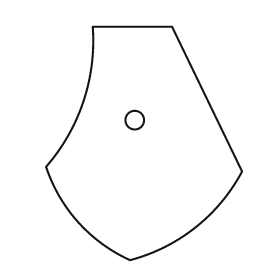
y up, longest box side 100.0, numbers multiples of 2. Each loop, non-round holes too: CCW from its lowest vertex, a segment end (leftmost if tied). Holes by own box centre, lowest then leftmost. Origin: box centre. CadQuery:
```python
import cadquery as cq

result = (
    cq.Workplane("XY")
    .moveTo(-6.0, -50.0)
    .threePointArc((22.0, -36.0), (42.0, -12.0))
    .lineTo(12.0, 50.0)
    .lineTo(-22.0, 50.0)
    .threePointArc((-26.0, 18.0), (-42.0, -10.0))
    .threePointArc((-28.0, -34.0), (-6.0, -50.0))
    .close()
    .moveTo(-4.0, 10.0)
    .circle(4.0)
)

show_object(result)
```